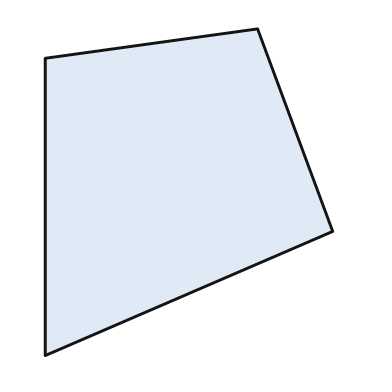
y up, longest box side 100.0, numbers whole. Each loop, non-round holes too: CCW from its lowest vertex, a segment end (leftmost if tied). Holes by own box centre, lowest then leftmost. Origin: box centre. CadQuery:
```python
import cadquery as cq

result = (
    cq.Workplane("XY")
    .moveTo(-44.0, -50.0)
    .lineTo(44.0, -12.0)
    .lineTo(21.0, 50.0)
    .lineTo(-44.0, 41.0)
    .close()
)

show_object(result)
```